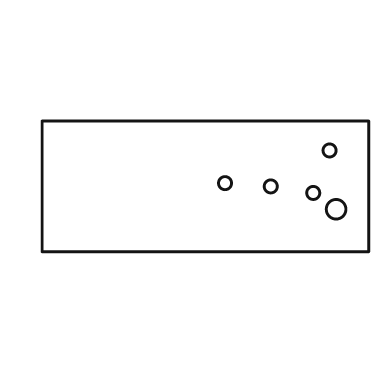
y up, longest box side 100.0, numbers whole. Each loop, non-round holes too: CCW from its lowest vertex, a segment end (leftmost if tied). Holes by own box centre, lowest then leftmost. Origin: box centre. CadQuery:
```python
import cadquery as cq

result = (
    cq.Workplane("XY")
    .moveTo(-50.0, -20.0)
    .lineTo(50.0, -20.0)
    .lineTo(50.0, 20.0)
    .lineTo(-50.0, 20.0)
    .close()
    .moveTo(40.0, -7.0)
    .circle(3.0)
    .moveTo(33.0, -2.0)
    .circle(2.0)
    .moveTo(20.0, 0.0)
    .circle(2.0)
    .moveTo(6.0, 1.0)
    .circle(2.0)
    .moveTo(38.0, 11.0)
    .circle(2.0)
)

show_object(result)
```